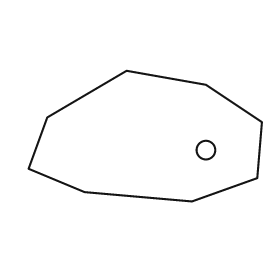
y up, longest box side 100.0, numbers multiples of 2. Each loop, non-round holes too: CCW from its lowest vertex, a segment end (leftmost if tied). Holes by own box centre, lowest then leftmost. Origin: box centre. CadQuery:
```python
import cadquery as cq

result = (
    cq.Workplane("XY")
    .moveTo(20.0, -28.0)
    .lineTo(48.0, -18.0)
    .lineTo(50.0, 6.0)
    .lineTo(26.0, 22.0)
    .lineTo(-8.0, 28.0)
    .lineTo(-42.0, 8.0)
    .lineTo(-50.0, -14.0)
    .lineTo(-26.0, -24.0)
    .close()
    .moveTo(26.0, -6.0)
    .circle(4.0)
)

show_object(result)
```